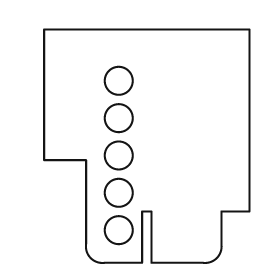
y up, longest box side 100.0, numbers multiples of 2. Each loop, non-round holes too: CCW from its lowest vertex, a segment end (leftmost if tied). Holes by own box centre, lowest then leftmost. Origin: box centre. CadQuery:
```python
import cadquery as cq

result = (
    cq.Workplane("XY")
    .moveTo(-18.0, -50.0)
    .lineTo(-2.0, -50.0)
    .lineTo(-2.0, -28.0)
    .lineTo(2.0, -28.0)
    .lineTo(2.0, -50.0)
    .lineTo(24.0, -50.0)
    .threePointArc((30.0, -48.0), (32.0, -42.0))
    .lineTo(32.0, -28.0)
    .lineTo(44.0, -28.0)
    .lineTo(44.0, 50.0)
    .lineTo(-44.0, 50.0)
    .lineTo(-44.0, -6.0)
    .lineTo(-26.0, -6.0)
    .lineTo(-26.0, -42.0)
    .threePointArc((-24.0, -48.0), (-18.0, -50.0))
    .close()
    .moveTo(-12.0, -36.0)
    .circle(6.0)
    .moveTo(-12.0, -20.0)
    .circle(6.0)
    .moveTo(-12.0, -4.0)
    .circle(6.0)
    .moveTo(-12.0, 12.0)
    .circle(6.0)
    .moveTo(-12.0, 28.0)
    .circle(6.0)
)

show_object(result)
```